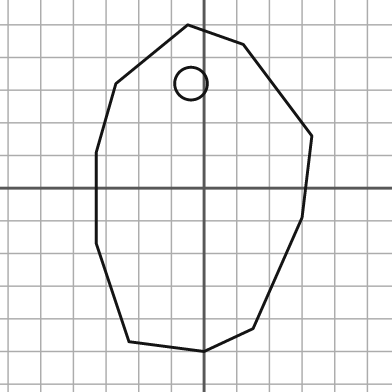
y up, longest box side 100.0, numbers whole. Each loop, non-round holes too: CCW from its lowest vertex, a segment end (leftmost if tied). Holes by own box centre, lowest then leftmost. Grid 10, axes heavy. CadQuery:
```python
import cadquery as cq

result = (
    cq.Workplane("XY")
    .moveTo(0.0, -50.0)
    .lineTo(15.0, -43.0)
    .lineTo(30.0, -9.0)
    .lineTo(33.0, 16.0)
    .lineTo(12.0, 44.0)
    .lineTo(-5.0, 50.0)
    .lineTo(-27.0, 32.0)
    .lineTo(-33.0, 11.0)
    .lineTo(-33.0, -17.0)
    .lineTo(-23.0, -47.0)
    .close()
    .moveTo(-4.0, 32.0)
    .circle(5.0)
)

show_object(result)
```